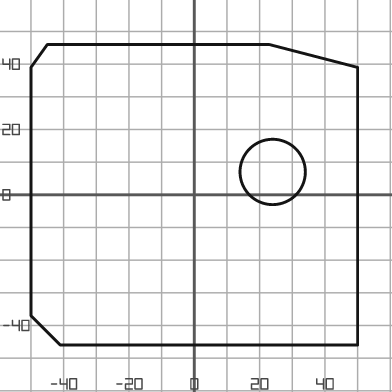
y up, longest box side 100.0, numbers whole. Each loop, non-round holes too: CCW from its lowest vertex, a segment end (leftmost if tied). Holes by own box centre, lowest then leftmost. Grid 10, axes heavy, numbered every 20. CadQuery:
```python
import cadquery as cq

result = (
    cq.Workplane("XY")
    .moveTo(-41.0, -46.0)
    .lineTo(50.0, -46.0)
    .lineTo(50.0, 39.0)
    .lineTo(23.0, 46.0)
    .lineTo(-45.0, 46.0)
    .lineTo(-50.0, 39.0)
    .lineTo(-50.0, -37.0)
    .close()
    .moveTo(24.0, 7.0)
    .circle(10.0)
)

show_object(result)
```